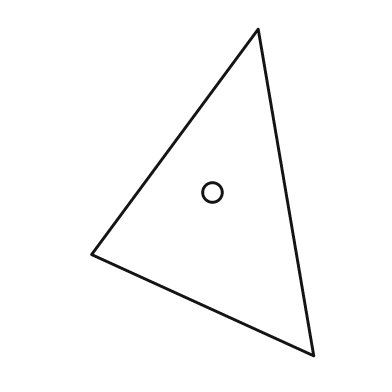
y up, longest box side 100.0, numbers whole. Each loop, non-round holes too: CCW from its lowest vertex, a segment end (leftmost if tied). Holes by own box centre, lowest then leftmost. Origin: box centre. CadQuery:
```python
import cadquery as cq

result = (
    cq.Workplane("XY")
    .moveTo(34.0, -50.0)
    .lineTo(17.0, 50.0)
    .lineTo(-34.0, -19.0)
    .close()
    .moveTo(3.0, 0.0)
    .circle(3.0)
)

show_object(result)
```